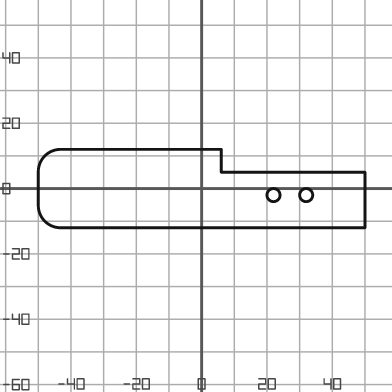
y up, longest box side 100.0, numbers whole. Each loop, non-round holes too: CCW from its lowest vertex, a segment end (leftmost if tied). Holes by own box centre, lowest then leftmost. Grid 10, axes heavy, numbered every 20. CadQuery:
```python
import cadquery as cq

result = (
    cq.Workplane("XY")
    .moveTo(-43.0, -12.0)
    .lineTo(50.0, -12.0)
    .lineTo(50.0, 5.0)
    .lineTo(6.0, 5.0)
    .lineTo(6.0, 12.0)
    .lineTo(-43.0, 12.0)
    .threePointArc((-48.0, 10.0), (-50.0, 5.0))
    .lineTo(-50.0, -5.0)
    .threePointArc((-48.0, -10.0), (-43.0, -12.0))
    .close()
    .moveTo(22.0, -2.0)
    .circle(2.0)
    .moveTo(32.0, -2.0)
    .circle(2.0)
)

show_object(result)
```